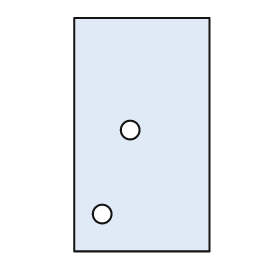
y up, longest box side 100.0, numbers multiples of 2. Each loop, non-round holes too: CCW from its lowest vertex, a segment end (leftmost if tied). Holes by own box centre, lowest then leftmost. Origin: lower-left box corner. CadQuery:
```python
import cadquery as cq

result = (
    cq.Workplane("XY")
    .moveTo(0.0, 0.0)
    .lineTo(58.0, 0.0)
    .lineTo(58.0, 100.0)
    .lineTo(0.0, 100.0)
    .close()
    .moveTo(12.0, 16.0)
    .circle(4.0)
    .moveTo(24.0, 52.0)
    .circle(4.0)
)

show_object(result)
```